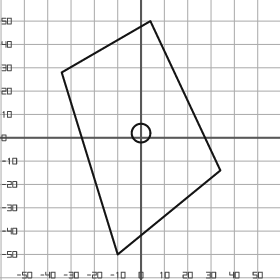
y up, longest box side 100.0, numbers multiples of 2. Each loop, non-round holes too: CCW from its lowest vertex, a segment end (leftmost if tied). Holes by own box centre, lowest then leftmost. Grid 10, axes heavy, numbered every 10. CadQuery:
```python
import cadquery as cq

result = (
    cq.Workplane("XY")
    .moveTo(-10.0, -50.0)
    .lineTo(34.0, -14.0)
    .lineTo(4.0, 50.0)
    .lineTo(-34.0, 28.0)
    .close()
    .moveTo(0.0, 2.0)
    .circle(4.0)
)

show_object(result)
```